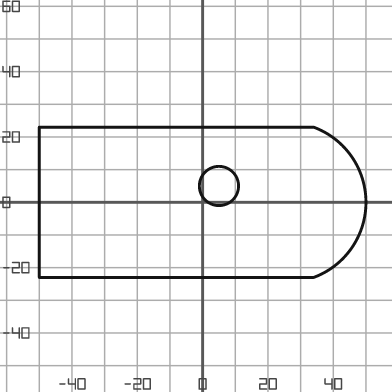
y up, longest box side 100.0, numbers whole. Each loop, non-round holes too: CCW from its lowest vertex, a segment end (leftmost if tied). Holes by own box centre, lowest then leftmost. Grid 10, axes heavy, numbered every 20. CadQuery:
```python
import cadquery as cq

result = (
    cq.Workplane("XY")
    .moveTo(-50.0, -23.0)
    .lineTo(34.0, -23.0)
    .threePointArc((50.0, 0.0), (34.0, 23.0))
    .lineTo(-50.0, 23.0)
    .close()
    .moveTo(5.0, 5.0)
    .circle(6.0)
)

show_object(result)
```